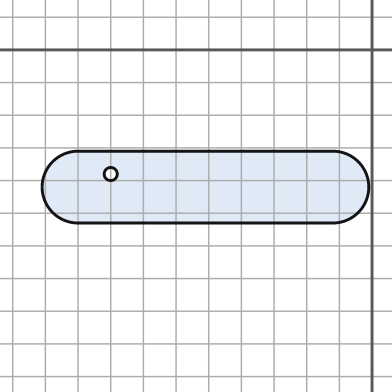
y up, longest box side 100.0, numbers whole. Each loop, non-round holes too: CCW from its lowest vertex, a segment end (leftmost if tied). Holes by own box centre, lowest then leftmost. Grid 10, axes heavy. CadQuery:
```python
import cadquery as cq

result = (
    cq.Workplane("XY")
    .moveTo(-90.0, -53.0)
    .lineTo(-12.0, -53.0)
    .threePointArc((-1.0, -42.0), (-12.0, -31.0))
    .lineTo(-90.0, -31.0)
    .threePointArc((-101.0, -42.0), (-90.0, -53.0))
    .close()
    .moveTo(-80.0, -38.0)
    .circle(2.0)
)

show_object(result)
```